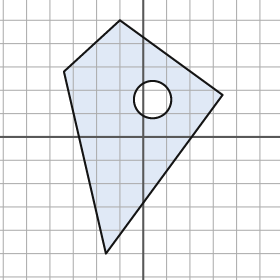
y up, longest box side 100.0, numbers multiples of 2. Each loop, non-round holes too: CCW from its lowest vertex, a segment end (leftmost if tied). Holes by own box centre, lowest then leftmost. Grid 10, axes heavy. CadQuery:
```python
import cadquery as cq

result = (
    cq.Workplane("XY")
    .moveTo(-16.0, -50.0)
    .lineTo(34.0, 18.0)
    .lineTo(-10.0, 50.0)
    .lineTo(-34.0, 28.0)
    .close()
    .moveTo(4.0, 16.0)
    .circle(8.0)
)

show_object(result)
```